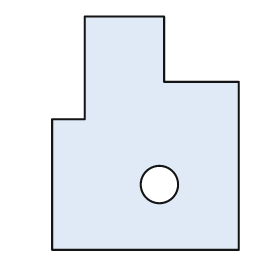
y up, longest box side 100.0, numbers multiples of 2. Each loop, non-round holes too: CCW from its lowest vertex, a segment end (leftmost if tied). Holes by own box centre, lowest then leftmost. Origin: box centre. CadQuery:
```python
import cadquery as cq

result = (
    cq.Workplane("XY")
    .moveTo(-40.0, -50.0)
    .lineTo(40.0, -50.0)
    .lineTo(40.0, 22.0)
    .lineTo(8.0, 22.0)
    .lineTo(8.0, 50.0)
    .lineTo(-26.0, 50.0)
    .lineTo(-26.0, 6.0)
    .lineTo(-40.0, 6.0)
    .close()
    .moveTo(6.0, -22.0)
    .circle(8.0)
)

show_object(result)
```